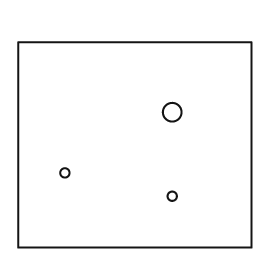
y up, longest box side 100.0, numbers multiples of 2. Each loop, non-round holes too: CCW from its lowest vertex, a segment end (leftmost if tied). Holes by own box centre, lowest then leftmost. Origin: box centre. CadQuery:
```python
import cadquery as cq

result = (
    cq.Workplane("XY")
    .moveTo(-50.0, -44.0)
    .lineTo(50.0, -44.0)
    .lineTo(50.0, 44.0)
    .lineTo(-50.0, 44.0)
    .close()
    .moveTo(16.0, -22.0)
    .circle(2.0)
    .moveTo(-30.0, -12.0)
    .circle(2.0)
    .moveTo(16.0, 14.0)
    .circle(4.0)
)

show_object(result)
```